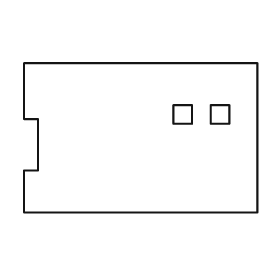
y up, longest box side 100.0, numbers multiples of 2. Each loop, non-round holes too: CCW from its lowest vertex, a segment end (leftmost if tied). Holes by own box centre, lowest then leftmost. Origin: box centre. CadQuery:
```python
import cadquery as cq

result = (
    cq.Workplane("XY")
    .moveTo(-50.0, -32.0)
    .lineTo(50.0, -32.0)
    .lineTo(50.0, 32.0)
    .lineTo(-50.0, 32.0)
    .lineTo(-50.0, 8.0)
    .lineTo(-44.0, 8.0)
    .lineTo(-44.0, -14.0)
    .lineTo(-50.0, -14.0)
    .close()
    .moveTo(14.0, 6.0)
    .lineTo(22.0, 6.0)
    .lineTo(22.0, 14.0)
    .lineTo(14.0, 14.0)
    .close()
    .moveTo(30.0, 6.0)
    .lineTo(38.0, 6.0)
    .lineTo(38.0, 14.0)
    .lineTo(30.0, 14.0)
    .close()
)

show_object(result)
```